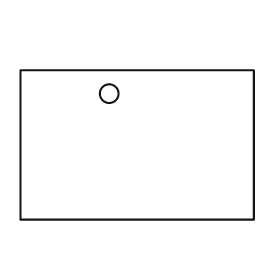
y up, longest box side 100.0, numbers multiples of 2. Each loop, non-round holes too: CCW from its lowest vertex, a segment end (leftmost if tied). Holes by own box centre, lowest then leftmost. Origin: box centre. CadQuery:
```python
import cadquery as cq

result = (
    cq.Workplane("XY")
    .moveTo(-50.0, -32.0)
    .lineTo(50.0, -32.0)
    .lineTo(50.0, 32.0)
    .lineTo(-50.0, 32.0)
    .close()
    .moveTo(-12.0, 22.0)
    .circle(4.0)
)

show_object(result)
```